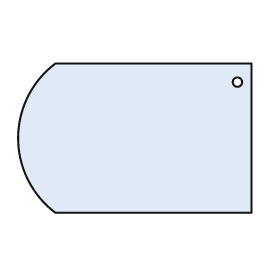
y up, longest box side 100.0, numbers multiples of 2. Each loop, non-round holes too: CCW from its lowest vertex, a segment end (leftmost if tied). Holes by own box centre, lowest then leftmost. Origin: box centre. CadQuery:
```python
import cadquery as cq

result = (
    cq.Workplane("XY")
    .moveTo(-34.0, -32.0)
    .lineTo(50.0, -32.0)
    .lineTo(50.0, 32.0)
    .lineTo(-34.0, 32.0)
    .threePointArc((-50.0, 0.0), (-34.0, -32.0))
    .close()
    .moveTo(44.0, 24.0)
    .circle(2.0)
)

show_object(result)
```